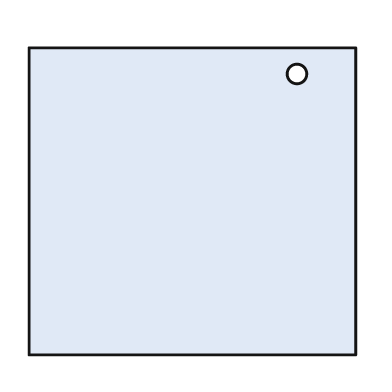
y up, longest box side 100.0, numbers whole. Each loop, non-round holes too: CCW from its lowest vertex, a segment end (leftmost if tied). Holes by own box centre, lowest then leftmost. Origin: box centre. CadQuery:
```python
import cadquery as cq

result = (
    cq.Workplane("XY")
    .moveTo(-50.0, -47.0)
    .lineTo(50.0, -47.0)
    .lineTo(50.0, 47.0)
    .lineTo(-50.0, 47.0)
    .close()
    .moveTo(32.0, 39.0)
    .circle(3.0)
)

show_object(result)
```